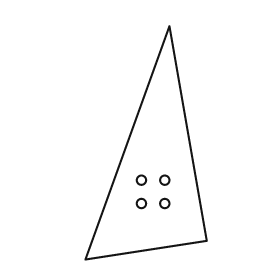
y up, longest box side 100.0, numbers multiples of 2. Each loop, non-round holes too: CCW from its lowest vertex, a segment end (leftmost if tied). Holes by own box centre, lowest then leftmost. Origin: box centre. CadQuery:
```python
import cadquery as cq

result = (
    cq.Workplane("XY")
    .moveTo(-26.0, -50.0)
    .lineTo(26.0, -42.0)
    .lineTo(10.0, 50.0)
    .close()
    .moveTo(-2.0, -26.0)
    .circle(2.0)
    .moveTo(8.0, -26.0)
    .circle(2.0)
    .moveTo(-2.0, -16.0)
    .circle(2.0)
    .moveTo(8.0, -16.0)
    .circle(2.0)
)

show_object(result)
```